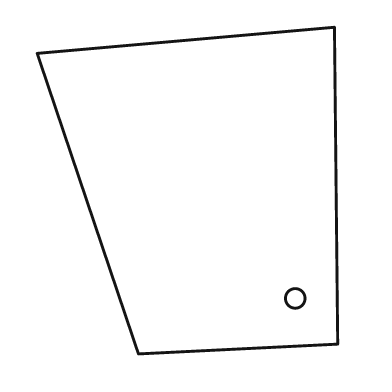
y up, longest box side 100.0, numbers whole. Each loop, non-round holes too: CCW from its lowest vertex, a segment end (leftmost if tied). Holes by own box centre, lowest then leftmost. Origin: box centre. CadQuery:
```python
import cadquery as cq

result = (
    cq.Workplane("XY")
    .moveTo(-15.0, -50.0)
    .lineTo(46.0, -47.0)
    .lineTo(45.0, 50.0)
    .lineTo(-46.0, 42.0)
    .close()
    .moveTo(33.0, -33.0)
    .circle(3.0)
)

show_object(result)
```